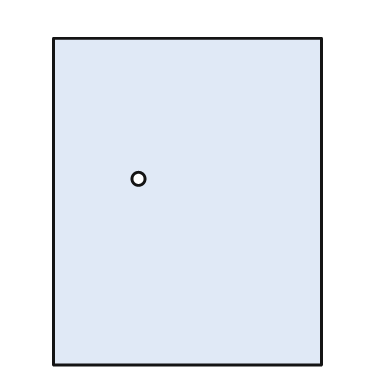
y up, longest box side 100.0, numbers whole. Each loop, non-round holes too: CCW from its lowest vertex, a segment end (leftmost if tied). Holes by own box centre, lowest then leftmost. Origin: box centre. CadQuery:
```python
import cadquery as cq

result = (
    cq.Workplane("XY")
    .moveTo(-41.0, -50.0)
    .lineTo(41.0, -50.0)
    .lineTo(41.0, 50.0)
    .lineTo(-41.0, 50.0)
    .close()
    .moveTo(-15.0, 7.0)
    .circle(2.0)
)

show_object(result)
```